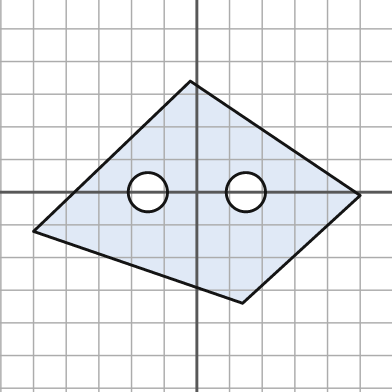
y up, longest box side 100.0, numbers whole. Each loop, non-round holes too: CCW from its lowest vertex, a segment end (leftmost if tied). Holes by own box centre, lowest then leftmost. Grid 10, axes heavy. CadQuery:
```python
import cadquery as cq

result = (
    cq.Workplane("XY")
    .moveTo(14.0, -34.0)
    .lineTo(50.0, -1.0)
    .lineTo(-2.0, 34.0)
    .lineTo(-50.0, -12.0)
    .close()
    .moveTo(-15.0, 0.0)
    .circle(6.0)
    .moveTo(15.0, 0.0)
    .circle(6.0)
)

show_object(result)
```